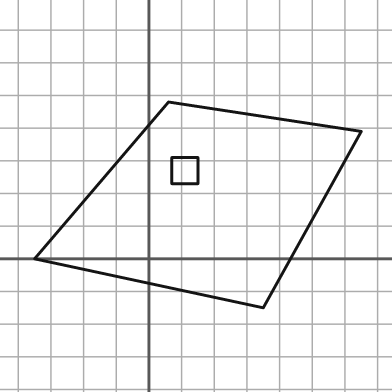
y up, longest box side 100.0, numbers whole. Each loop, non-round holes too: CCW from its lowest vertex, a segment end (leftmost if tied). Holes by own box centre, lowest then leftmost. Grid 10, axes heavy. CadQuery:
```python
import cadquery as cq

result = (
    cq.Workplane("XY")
    .moveTo(35.0, -15.0)
    .lineTo(65.0, 39.0)
    .lineTo(6.0, 48.0)
    .lineTo(-35.0, 0.0)
    .close()
    .moveTo(7.0, 23.0)
    .lineTo(15.0, 23.0)
    .lineTo(15.0, 31.0)
    .lineTo(7.0, 31.0)
    .close()
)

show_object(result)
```